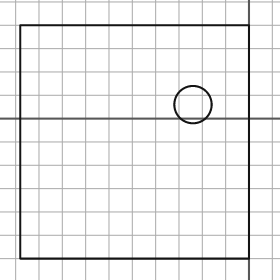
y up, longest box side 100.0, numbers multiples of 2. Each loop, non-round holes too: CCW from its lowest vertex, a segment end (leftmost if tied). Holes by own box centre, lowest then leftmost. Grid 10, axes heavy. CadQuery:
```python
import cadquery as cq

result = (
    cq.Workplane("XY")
    .moveTo(-98.0, -60.0)
    .lineTo(0.0, -60.0)
    .lineTo(0.0, 40.0)
    .lineTo(-98.0, 40.0)
    .close()
    .moveTo(-24.0, 6.0)
    .circle(8.0)
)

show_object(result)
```